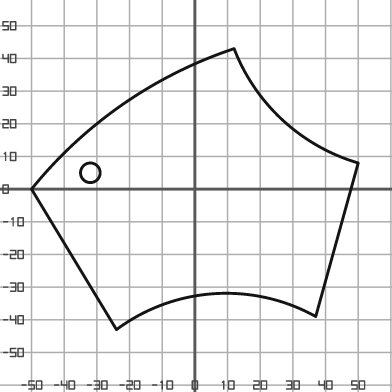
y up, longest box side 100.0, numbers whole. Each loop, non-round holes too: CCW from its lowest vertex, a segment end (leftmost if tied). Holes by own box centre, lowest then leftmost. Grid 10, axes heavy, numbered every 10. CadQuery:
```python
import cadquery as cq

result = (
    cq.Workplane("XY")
    .moveTo(-24.0, -43.0)
    .threePointArc((6.0, -32.0), (37.0, -39.0))
    .lineTo(50.0, 8.0)
    .threePointArc((27.0, 21.0), (12.0, 43.0))
    .threePointArc((-22.0, 26.0), (-50.0, 0.0))
    .close()
    .moveTo(-32.0, 5.0)
    .circle(3.0)
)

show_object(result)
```